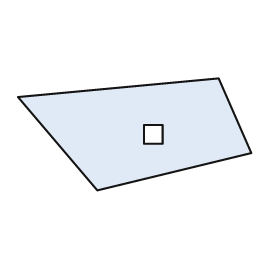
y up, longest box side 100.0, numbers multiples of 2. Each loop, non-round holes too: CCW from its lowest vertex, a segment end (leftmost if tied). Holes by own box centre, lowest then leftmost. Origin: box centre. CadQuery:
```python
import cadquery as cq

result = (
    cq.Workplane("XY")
    .moveTo(-16.0, -24.0)
    .lineTo(50.0, -8.0)
    .lineTo(36.0, 24.0)
    .lineTo(-50.0, 16.0)
    .close()
    .moveTo(4.0, -4.0)
    .lineTo(12.0, -4.0)
    .lineTo(12.0, 4.0)
    .lineTo(4.0, 4.0)
    .close()
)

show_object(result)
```